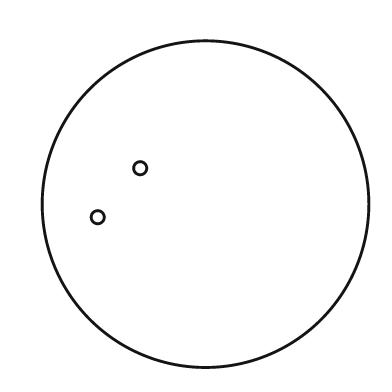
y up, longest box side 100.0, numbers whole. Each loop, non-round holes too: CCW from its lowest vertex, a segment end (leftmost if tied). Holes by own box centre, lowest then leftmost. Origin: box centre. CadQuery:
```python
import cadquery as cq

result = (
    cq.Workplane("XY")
    .moveTo(0.0, 0.0)
    .circle(50.0)
    .moveTo(-33.0, -4.0)
    .circle(2.0)
    .moveTo(-20.0, 11.0)
    .circle(2.0)
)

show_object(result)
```